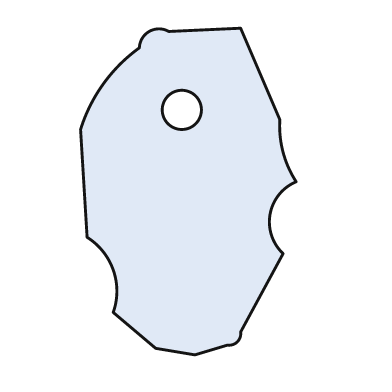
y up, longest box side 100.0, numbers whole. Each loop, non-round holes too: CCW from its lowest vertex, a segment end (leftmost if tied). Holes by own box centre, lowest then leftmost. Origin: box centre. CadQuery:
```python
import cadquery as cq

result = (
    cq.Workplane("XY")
    .moveTo(2.0, -50.0)
    .lineTo(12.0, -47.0)
    .threePointArc((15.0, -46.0), (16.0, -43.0))
    .lineTo(29.0, -19.0)
    .threePointArc((25.0, -7.0), (33.0, 3.0))
    .threePointArc((29.0, 12.0), (28.0, 22.0))
    .lineTo(16.0, 50.0)
    .lineTo(-6.0, 49.0)
    .threePointArc((-12.0, 49.0), (-15.0, 44.0))
    .threePointArc((-26.0, 33.0), (-33.0, 19.0))
    .lineTo(-31.0, -14.0)
    .threePointArc((-23.0, -24.0), (-23.0, -37.0))
    .lineTo(-10.0, -48.0)
    .close()
    .moveTo(-2.0, 25.0)
    .circle(6.0)
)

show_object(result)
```